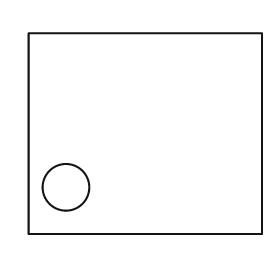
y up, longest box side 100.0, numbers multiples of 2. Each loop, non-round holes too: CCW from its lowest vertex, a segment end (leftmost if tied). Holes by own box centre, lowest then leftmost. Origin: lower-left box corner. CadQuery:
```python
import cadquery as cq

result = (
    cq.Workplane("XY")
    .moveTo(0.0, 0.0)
    .lineTo(100.0, 0.0)
    .lineTo(100.0, 86.0)
    .lineTo(0.0, 86.0)
    .close()
    .moveTo(16.0, 20.0)
    .circle(10.0)
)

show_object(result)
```